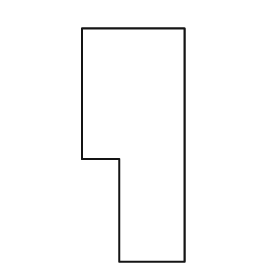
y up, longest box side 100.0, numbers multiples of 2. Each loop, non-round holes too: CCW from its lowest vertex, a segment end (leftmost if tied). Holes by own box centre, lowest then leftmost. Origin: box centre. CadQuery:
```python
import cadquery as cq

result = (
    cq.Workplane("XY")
    .moveTo(-6.0, -50.0)
    .lineTo(22.0, -50.0)
    .lineTo(22.0, 50.0)
    .lineTo(-22.0, 50.0)
    .lineTo(-22.0, -6.0)
    .lineTo(-6.0, -6.0)
    .close()
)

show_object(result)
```